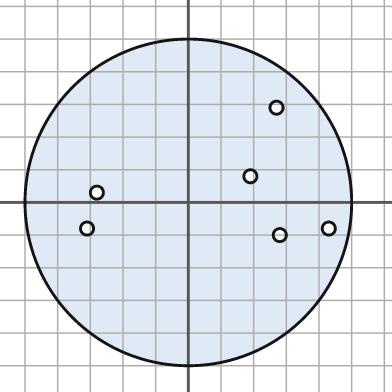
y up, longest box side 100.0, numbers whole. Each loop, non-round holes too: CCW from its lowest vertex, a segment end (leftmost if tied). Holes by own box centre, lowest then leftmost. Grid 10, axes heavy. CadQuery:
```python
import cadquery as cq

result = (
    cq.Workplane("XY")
    .moveTo(0.0, 0.0)
    .circle(50.0)
    .moveTo(28.0, -10.0)
    .circle(2.0)
    .moveTo(-31.0, -8.0)
    .circle(2.0)
    .moveTo(43.0, -8.0)
    .circle(2.0)
    .moveTo(-28.0, 3.0)
    .circle(2.0)
    .moveTo(19.0, 8.0)
    .circle(2.0)
    .moveTo(27.0, 29.0)
    .circle(2.0)
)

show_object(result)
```